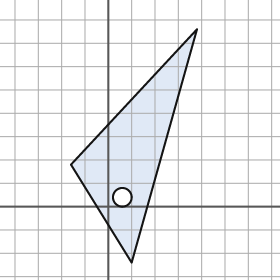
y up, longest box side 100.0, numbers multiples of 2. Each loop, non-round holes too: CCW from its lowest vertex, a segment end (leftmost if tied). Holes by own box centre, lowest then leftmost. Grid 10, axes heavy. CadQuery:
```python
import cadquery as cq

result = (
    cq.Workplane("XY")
    .moveTo(10.0, -24.0)
    .lineTo(38.0, 76.0)
    .lineTo(-16.0, 18.0)
    .close()
    .moveTo(6.0, 4.0)
    .circle(4.0)
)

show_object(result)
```